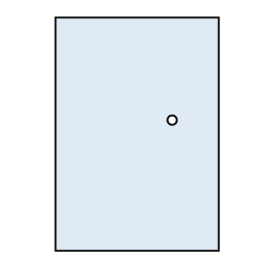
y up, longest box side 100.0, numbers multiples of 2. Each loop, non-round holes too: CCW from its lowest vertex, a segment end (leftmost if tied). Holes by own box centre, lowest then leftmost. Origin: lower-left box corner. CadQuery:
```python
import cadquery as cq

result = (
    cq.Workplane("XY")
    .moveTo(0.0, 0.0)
    .lineTo(70.0, 0.0)
    .lineTo(70.0, 100.0)
    .lineTo(0.0, 100.0)
    .close()
    .moveTo(50.0, 56.0)
    .circle(2.0)
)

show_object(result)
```